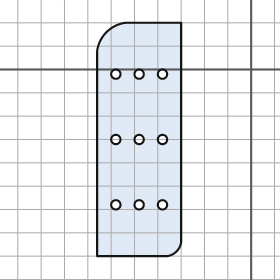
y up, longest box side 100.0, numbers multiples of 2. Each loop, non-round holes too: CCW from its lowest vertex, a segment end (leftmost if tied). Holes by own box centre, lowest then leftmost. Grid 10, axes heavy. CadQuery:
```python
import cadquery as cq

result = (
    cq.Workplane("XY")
    .moveTo(-66.0, -80.0)
    .lineTo(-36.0, -80.0)
    .threePointArc((-32.0, -78.0), (-30.0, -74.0))
    .lineTo(-30.0, 20.0)
    .lineTo(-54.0, 20.0)
    .threePointArc((-62.0, 16.0), (-66.0, 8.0))
    .close()
    .moveTo(-58.0, -58.0)
    .circle(2.0)
    .moveTo(-48.0, -58.0)
    .circle(2.0)
    .moveTo(-38.0, -58.0)
    .circle(2.0)
    .moveTo(-58.0, -30.0)
    .circle(2.0)
    .moveTo(-48.0, -30.0)
    .circle(2.0)
    .moveTo(-38.0, -30.0)
    .circle(2.0)
    .moveTo(-58.0, -2.0)
    .circle(2.0)
    .moveTo(-48.0, -2.0)
    .circle(2.0)
    .moveTo(-38.0, -2.0)
    .circle(2.0)
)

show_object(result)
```